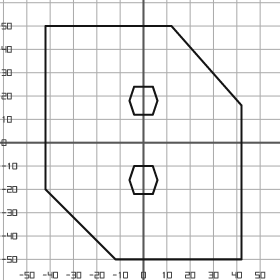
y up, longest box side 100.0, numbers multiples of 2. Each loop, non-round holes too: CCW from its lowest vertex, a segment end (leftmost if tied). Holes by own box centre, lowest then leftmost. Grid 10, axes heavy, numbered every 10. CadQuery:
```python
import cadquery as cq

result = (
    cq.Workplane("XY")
    .moveTo(-12.0, -50.0)
    .lineTo(42.0, -50.0)
    .lineTo(42.0, 16.0)
    .lineTo(12.0, 50.0)
    .lineTo(-42.0, 50.0)
    .lineTo(-42.0, -20.0)
    .close()
    .moveTo(-4.0, -22.0)
    .lineTo(4.0, -22.0)
    .lineTo(6.0, -16.0)
    .lineTo(4.0, -10.0)
    .lineTo(-4.0, -10.0)
    .lineTo(-6.0, -16.0)
    .close()
    .moveTo(-4.0, 12.0)
    .lineTo(4.0, 12.0)
    .lineTo(6.0, 18.0)
    .lineTo(4.0, 24.0)
    .lineTo(-4.0, 24.0)
    .lineTo(-6.0, 18.0)
    .close()
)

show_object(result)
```